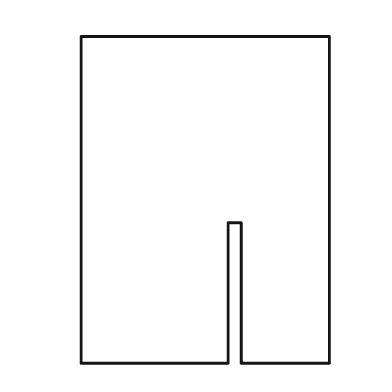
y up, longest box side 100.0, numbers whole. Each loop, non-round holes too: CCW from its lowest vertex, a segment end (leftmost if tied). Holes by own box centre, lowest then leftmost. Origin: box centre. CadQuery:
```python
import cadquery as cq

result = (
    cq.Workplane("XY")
    .moveTo(-38.0, -50.0)
    .lineTo(7.0, -50.0)
    .lineTo(7.0, -7.0)
    .lineTo(11.0, -7.0)
    .lineTo(11.0, -50.0)
    .lineTo(38.0, -50.0)
    .lineTo(38.0, 50.0)
    .lineTo(-38.0, 50.0)
    .close()
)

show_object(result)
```